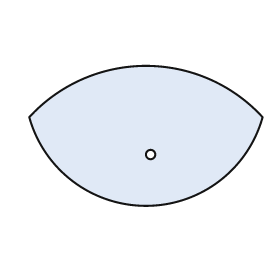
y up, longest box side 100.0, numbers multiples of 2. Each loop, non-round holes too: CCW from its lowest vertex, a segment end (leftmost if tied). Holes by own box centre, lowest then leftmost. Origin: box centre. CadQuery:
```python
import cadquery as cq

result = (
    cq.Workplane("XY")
    .moveTo(-50.0, 8.0)
    .threePointArc((0.0, -30.0), (50.0, 8.0))
    .threePointArc((0.0, 30.0), (-50.0, 8.0))
    .close()
    .moveTo(2.0, -8.0)
    .circle(2.0)
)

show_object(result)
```